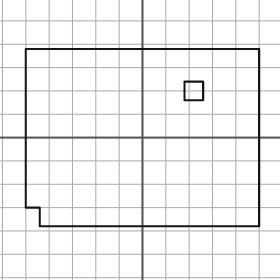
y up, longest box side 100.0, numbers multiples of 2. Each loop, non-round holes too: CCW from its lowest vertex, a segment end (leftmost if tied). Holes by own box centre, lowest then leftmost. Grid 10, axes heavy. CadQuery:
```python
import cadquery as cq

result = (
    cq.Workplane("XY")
    .moveTo(-44.0, -38.0)
    .lineTo(50.0, -38.0)
    .lineTo(50.0, 38.0)
    .lineTo(-50.0, 38.0)
    .lineTo(-50.0, -30.0)
    .lineTo(-44.0, -30.0)
    .close()
    .moveTo(18.0, 16.0)
    .lineTo(26.0, 16.0)
    .lineTo(26.0, 24.0)
    .lineTo(18.0, 24.0)
    .close()
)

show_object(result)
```